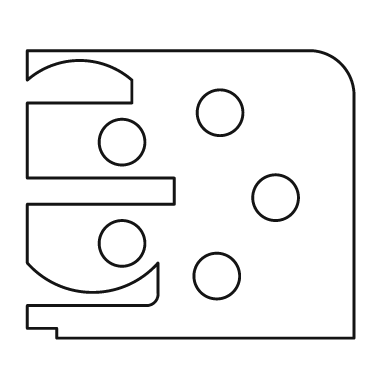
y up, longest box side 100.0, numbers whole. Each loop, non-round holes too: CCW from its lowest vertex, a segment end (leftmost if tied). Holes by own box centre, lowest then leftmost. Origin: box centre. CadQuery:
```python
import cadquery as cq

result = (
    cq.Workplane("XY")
    .moveTo(-41.0, -44.0)
    .lineTo(50.0, -44.0)
    .lineTo(50.0, 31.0)
    .threePointArc((46.0, 40.0), (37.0, 44.0))
    .lineTo(-50.0, 44.0)
    .lineTo(-50.0, 35.0)
    .threePointArc((-34.0, 41.0), (-18.0, 35.0))
    .lineTo(-18.0, 28.0)
    .lineTo(-50.0, 28.0)
    .lineTo(-50.0, 5.0)
    .lineTo(-5.0, 5.0)
    .lineTo(-5.0, -3.0)
    .lineTo(-50.0, -3.0)
    .lineTo(-50.0, -21.0)
    .threePointArc((-30.0, -30.0), (-10.0, -21.0))
    .lineTo(-10.0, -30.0)
    .threePointArc((-11.0, -33.0), (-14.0, -34.0))
    .lineTo(-50.0, -34.0)
    .lineTo(-50.0, -41.0)
    .lineTo(-41.0, -41.0)
    .close()
    .moveTo(8.0, -25.0)
    .circle(7.0)
    .moveTo(-21.0, -15.0)
    .circle(7.0)
    .moveTo(26.0, -1.0)
    .circle(7.0)
    .moveTo(-21.0, 16.0)
    .circle(7.0)
    .moveTo(9.0, 25.0)
    .circle(7.0)
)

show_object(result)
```